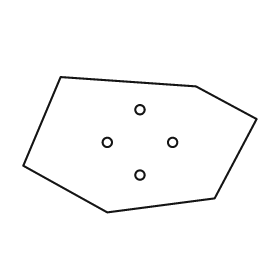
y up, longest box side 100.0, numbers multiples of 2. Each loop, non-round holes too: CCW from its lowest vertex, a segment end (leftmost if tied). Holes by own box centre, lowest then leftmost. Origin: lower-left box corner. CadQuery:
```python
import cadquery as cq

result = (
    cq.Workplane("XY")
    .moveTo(36.0, 0.0)
    .lineTo(82.0, 6.0)
    .lineTo(100.0, 40.0)
    .lineTo(74.0, 54.0)
    .lineTo(16.0, 58.0)
    .lineTo(0.0, 20.0)
    .close()
    .moveTo(50.0, 16.0)
    .circle(2.0)
    .moveTo(36.0, 30.0)
    .circle(2.0)
    .moveTo(64.0, 30.0)
    .circle(2.0)
    .moveTo(50.0, 44.0)
    .circle(2.0)
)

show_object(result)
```